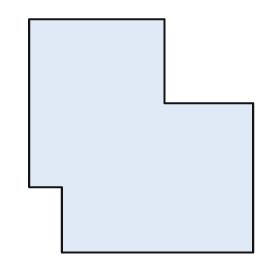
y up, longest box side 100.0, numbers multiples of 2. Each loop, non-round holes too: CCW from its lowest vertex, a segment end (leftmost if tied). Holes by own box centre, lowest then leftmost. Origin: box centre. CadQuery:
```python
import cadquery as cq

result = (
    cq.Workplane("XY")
    .moveTo(-34.0, -50.0)
    .lineTo(48.0, -50.0)
    .lineTo(48.0, 14.0)
    .lineTo(10.0, 14.0)
    .lineTo(10.0, 50.0)
    .lineTo(-48.0, 50.0)
    .lineTo(-48.0, -22.0)
    .lineTo(-34.0, -22.0)
    .close()
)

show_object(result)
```